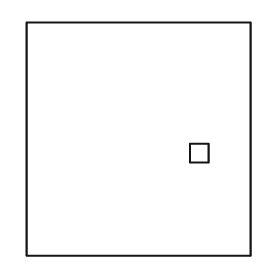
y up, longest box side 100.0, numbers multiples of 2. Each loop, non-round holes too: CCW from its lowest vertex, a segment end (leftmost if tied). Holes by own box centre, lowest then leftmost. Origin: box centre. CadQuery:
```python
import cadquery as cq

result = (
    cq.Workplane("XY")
    .moveTo(-48.0, -50.0)
    .lineTo(48.0, -50.0)
    .lineTo(48.0, 50.0)
    .lineTo(-48.0, 50.0)
    .close()
    .moveTo(22.0, -10.0)
    .lineTo(30.0, -10.0)
    .lineTo(30.0, -2.0)
    .lineTo(22.0, -2.0)
    .close()
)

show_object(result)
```